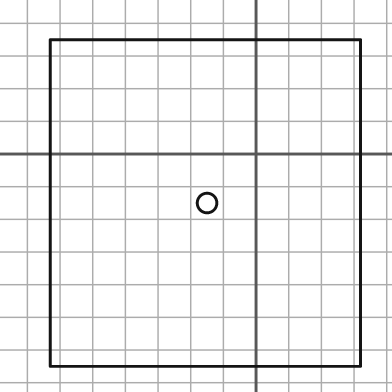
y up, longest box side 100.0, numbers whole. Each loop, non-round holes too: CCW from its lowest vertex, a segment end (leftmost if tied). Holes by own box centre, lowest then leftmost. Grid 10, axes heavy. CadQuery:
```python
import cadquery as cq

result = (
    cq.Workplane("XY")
    .moveTo(-63.0, -65.0)
    .lineTo(32.0, -65.0)
    .lineTo(32.0, 35.0)
    .lineTo(-63.0, 35.0)
    .close()
    .moveTo(-15.0, -15.0)
    .circle(3.0)
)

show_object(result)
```